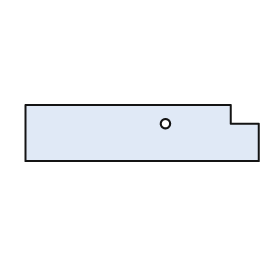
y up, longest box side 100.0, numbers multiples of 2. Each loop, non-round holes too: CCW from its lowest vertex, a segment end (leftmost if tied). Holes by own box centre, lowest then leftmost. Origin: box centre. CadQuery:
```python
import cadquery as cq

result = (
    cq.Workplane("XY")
    .moveTo(-50.0, -12.0)
    .lineTo(50.0, -12.0)
    .lineTo(50.0, 4.0)
    .lineTo(38.0, 4.0)
    .lineTo(38.0, 12.0)
    .lineTo(-50.0, 12.0)
    .close()
    .moveTo(10.0, 4.0)
    .circle(2.0)
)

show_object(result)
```